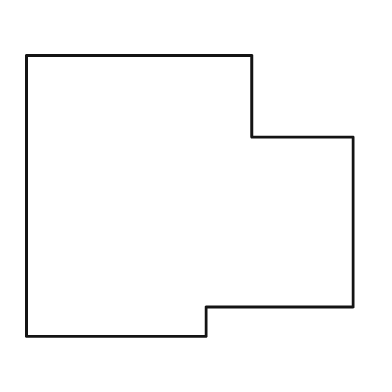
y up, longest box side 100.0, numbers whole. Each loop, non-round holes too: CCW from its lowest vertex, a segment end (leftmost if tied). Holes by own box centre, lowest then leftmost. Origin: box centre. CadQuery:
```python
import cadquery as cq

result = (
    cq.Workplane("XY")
    .moveTo(-50.0, -43.0)
    .lineTo(5.0, -43.0)
    .lineTo(5.0, -34.0)
    .lineTo(50.0, -34.0)
    .lineTo(50.0, 18.0)
    .lineTo(19.0, 18.0)
    .lineTo(19.0, 43.0)
    .lineTo(-50.0, 43.0)
    .close()
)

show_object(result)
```